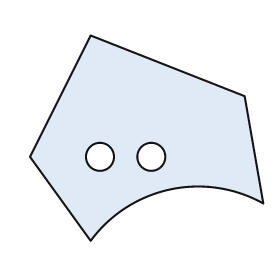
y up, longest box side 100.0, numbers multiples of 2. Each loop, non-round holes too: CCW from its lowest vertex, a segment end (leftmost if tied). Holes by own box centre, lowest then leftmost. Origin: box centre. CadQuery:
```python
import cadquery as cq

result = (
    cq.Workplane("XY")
    .moveTo(-24.0, -44.0)
    .threePointArc((10.0, -22.0), (50.0, -28.0))
    .lineTo(42.0, 18.0)
    .lineTo(-24.0, 44.0)
    .lineTo(-50.0, -8.0)
    .close()
    .moveTo(-20.0, -8.0)
    .circle(6.0)
    .moveTo(2.0, -8.0)
    .circle(6.0)
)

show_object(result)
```